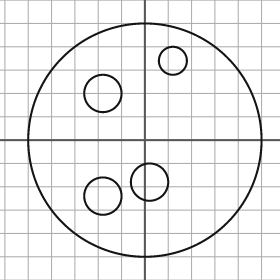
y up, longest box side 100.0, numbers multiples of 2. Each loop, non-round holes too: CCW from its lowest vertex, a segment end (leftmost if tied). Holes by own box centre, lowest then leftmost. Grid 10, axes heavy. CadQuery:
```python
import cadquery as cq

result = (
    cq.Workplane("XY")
    .moveTo(0.0, 0.0)
    .circle(50.0)
    .moveTo(-18.0, -24.0)
    .circle(8.0)
    .moveTo(2.0, -18.0)
    .circle(8.0)
    .moveTo(-18.0, 20.0)
    .circle(8.0)
    .moveTo(12.0, 34.0)
    .circle(6.0)
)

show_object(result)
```